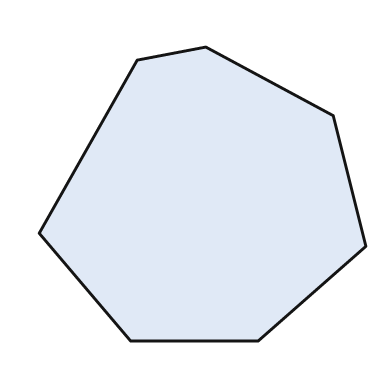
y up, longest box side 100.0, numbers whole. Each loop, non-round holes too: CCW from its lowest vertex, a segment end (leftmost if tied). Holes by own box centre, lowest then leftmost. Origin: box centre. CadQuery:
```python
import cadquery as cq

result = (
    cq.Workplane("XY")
    .moveTo(-22.0, -45.0)
    .lineTo(17.0, -45.0)
    .lineTo(50.0, -16.0)
    .lineTo(40.0, 24.0)
    .lineTo(1.0, 45.0)
    .lineTo(-20.0, 41.0)
    .lineTo(-50.0, -12.0)
    .close()
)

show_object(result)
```